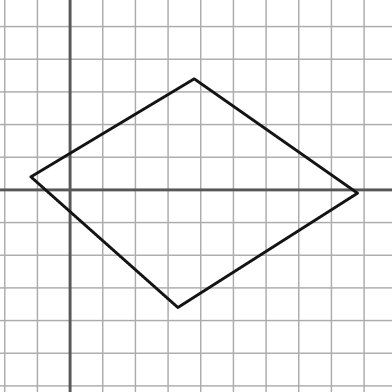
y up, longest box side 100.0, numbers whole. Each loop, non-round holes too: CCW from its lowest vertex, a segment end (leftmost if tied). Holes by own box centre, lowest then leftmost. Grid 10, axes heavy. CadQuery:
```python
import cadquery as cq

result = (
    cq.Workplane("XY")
    .moveTo(33.0, -36.0)
    .lineTo(88.0, -1.0)
    .lineTo(38.0, 34.0)
    .lineTo(-12.0, 4.0)
    .close()
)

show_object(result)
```